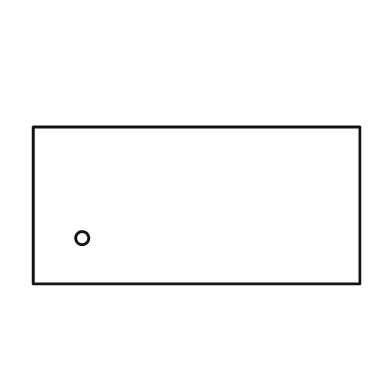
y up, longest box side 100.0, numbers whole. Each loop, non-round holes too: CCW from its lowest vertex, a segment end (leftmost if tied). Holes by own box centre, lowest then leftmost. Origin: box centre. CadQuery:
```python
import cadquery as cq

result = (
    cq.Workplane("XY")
    .moveTo(-50.0, -24.0)
    .lineTo(50.0, -24.0)
    .lineTo(50.0, 24.0)
    .lineTo(-50.0, 24.0)
    .close()
    .moveTo(-35.0, -10.0)
    .circle(2.0)
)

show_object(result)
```